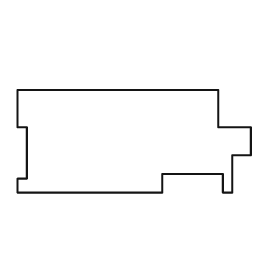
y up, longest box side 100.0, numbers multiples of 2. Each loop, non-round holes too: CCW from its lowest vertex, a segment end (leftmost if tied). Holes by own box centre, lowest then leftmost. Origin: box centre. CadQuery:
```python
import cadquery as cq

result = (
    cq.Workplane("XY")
    .moveTo(-50.0, -22.0)
    .lineTo(12.0, -22.0)
    .lineTo(12.0, -14.0)
    .lineTo(38.0, -14.0)
    .lineTo(38.0, -22.0)
    .lineTo(42.0, -22.0)
    .lineTo(42.0, -6.0)
    .lineTo(50.0, -6.0)
    .lineTo(50.0, 6.0)
    .lineTo(36.0, 6.0)
    .lineTo(36.0, 22.0)
    .lineTo(-50.0, 22.0)
    .lineTo(-50.0, 6.0)
    .lineTo(-46.0, 6.0)
    .lineTo(-46.0, -16.0)
    .lineTo(-50.0, -16.0)
    .close()
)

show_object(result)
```